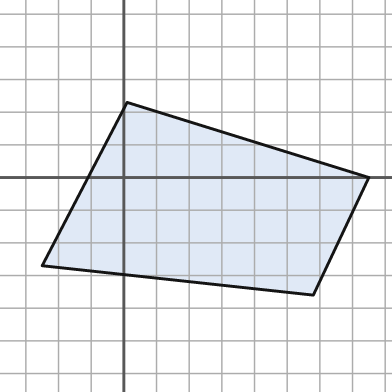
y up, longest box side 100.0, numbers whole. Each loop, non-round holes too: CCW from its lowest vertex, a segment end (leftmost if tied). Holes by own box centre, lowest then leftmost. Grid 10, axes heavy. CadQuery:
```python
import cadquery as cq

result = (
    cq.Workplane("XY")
    .moveTo(58.0, -36.0)
    .lineTo(75.0, 0.0)
    .lineTo(1.0, 23.0)
    .lineTo(-25.0, -27.0)
    .close()
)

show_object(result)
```